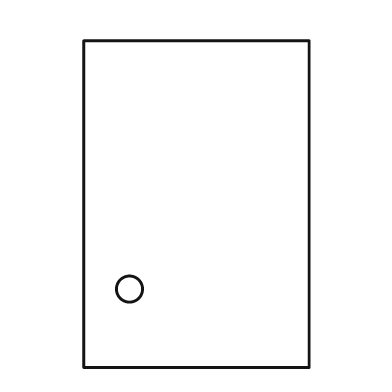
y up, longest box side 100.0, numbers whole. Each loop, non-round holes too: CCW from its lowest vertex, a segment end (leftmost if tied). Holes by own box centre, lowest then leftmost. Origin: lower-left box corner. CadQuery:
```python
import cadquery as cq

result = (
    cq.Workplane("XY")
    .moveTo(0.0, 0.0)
    .lineTo(69.0, 0.0)
    .lineTo(69.0, 100.0)
    .lineTo(0.0, 100.0)
    .close()
    .moveTo(14.0, 24.0)
    .circle(4.0)
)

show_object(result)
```